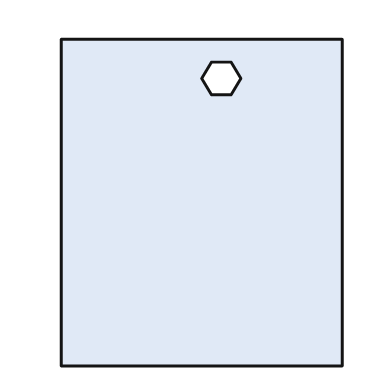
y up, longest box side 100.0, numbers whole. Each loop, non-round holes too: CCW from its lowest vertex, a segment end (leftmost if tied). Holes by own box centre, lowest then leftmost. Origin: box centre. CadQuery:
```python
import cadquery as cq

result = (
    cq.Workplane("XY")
    .moveTo(-43.0, -50.0)
    .lineTo(43.0, -50.0)
    .lineTo(43.0, 50.0)
    .lineTo(-43.0, 50.0)
    .close()
    .moveTo(3.0, 33.0)
    .lineTo(9.0, 33.0)
    .lineTo(12.0, 38.0)
    .lineTo(9.0, 43.0)
    .lineTo(3.0, 43.0)
    .lineTo(0.0, 38.0)
    .close()
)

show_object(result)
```